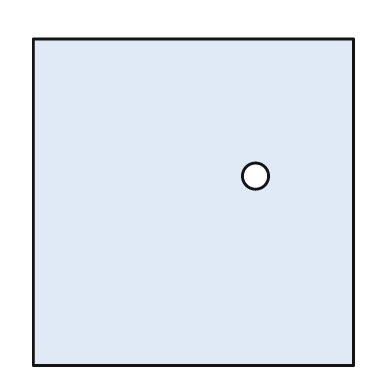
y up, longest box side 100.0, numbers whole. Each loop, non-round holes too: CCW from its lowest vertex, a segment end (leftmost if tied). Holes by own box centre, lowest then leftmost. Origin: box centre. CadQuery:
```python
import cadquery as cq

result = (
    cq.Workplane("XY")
    .moveTo(-49.0, -50.0)
    .lineTo(49.0, -50.0)
    .lineTo(49.0, 50.0)
    .lineTo(-49.0, 50.0)
    .close()
    .moveTo(19.0, 8.0)
    .circle(4.0)
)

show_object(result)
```